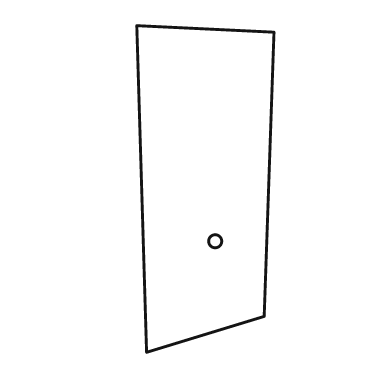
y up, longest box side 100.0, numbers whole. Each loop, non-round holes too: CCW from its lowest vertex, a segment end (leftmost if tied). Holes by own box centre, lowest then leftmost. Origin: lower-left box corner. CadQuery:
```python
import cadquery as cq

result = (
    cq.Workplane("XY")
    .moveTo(3.0, 0.0)
    .lineTo(39.0, 11.0)
    .lineTo(42.0, 98.0)
    .lineTo(0.0, 100.0)
    .close()
    .moveTo(24.0, 34.0)
    .circle(2.0)
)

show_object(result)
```